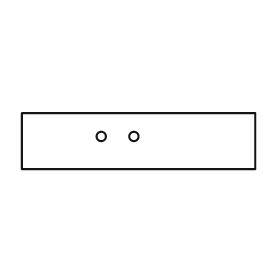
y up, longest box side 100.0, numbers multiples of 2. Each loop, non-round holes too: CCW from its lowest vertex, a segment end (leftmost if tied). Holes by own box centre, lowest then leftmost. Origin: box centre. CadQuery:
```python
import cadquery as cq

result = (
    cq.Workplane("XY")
    .moveTo(-50.0, -12.0)
    .lineTo(50.0, -12.0)
    .lineTo(50.0, 12.0)
    .lineTo(-50.0, 12.0)
    .close()
    .moveTo(-16.0, 2.0)
    .circle(2.0)
    .moveTo(-2.0, 2.0)
    .circle(2.0)
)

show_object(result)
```